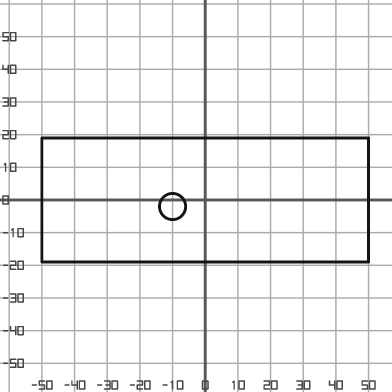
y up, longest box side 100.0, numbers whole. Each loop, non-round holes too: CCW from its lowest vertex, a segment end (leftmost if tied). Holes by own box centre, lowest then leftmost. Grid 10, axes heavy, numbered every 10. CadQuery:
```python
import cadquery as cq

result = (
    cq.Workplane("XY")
    .moveTo(-50.0, -19.0)
    .lineTo(50.0, -19.0)
    .lineTo(50.0, 19.0)
    .lineTo(-50.0, 19.0)
    .close()
    .moveTo(-10.0, -2.0)
    .circle(4.0)
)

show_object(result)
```